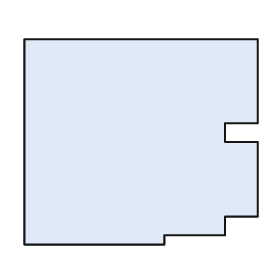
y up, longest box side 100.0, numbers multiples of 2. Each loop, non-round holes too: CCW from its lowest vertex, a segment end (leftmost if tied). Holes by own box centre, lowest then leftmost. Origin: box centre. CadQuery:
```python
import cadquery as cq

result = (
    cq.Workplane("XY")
    .moveTo(-50.0, -44.0)
    .lineTo(10.0, -44.0)
    .lineTo(10.0, -40.0)
    .lineTo(36.0, -40.0)
    .lineTo(36.0, -32.0)
    .lineTo(50.0, -32.0)
    .lineTo(50.0, 0.0)
    .lineTo(36.0, 0.0)
    .lineTo(36.0, 8.0)
    .lineTo(50.0, 8.0)
    .lineTo(50.0, 44.0)
    .lineTo(-50.0, 44.0)
    .close()
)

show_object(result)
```